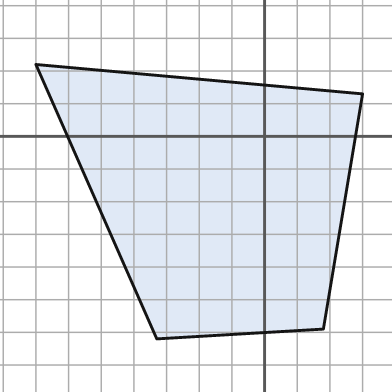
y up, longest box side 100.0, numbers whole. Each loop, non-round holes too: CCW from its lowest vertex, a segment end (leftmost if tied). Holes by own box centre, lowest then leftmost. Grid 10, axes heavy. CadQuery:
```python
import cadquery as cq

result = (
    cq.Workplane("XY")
    .moveTo(-33.0, -62.0)
    .lineTo(18.0, -59.0)
    .lineTo(30.0, 13.0)
    .lineTo(-70.0, 22.0)
    .close()
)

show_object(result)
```